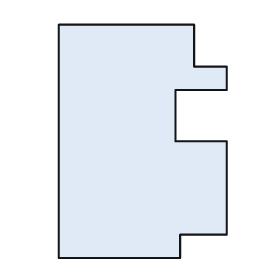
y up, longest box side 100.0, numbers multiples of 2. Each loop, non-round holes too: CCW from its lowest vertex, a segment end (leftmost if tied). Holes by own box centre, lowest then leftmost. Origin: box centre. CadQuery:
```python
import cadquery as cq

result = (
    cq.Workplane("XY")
    .moveTo(-36.0, -50.0)
    .lineTo(16.0, -50.0)
    .lineTo(16.0, -40.0)
    .lineTo(36.0, -40.0)
    .lineTo(36.0, 0.0)
    .lineTo(14.0, 0.0)
    .lineTo(14.0, 22.0)
    .lineTo(36.0, 22.0)
    .lineTo(36.0, 32.0)
    .lineTo(22.0, 32.0)
    .lineTo(22.0, 50.0)
    .lineTo(-36.0, 50.0)
    .close()
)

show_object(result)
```